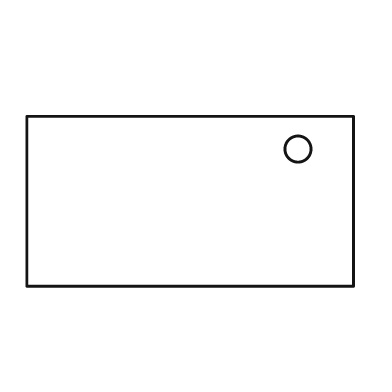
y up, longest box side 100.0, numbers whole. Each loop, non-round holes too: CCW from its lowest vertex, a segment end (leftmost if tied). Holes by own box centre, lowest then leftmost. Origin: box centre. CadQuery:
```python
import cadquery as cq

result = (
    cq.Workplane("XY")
    .moveTo(-50.0, -26.0)
    .lineTo(50.0, -26.0)
    .lineTo(50.0, 26.0)
    .lineTo(-50.0, 26.0)
    .close()
    .moveTo(33.0, 16.0)
    .circle(4.0)
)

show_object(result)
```